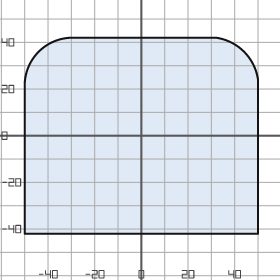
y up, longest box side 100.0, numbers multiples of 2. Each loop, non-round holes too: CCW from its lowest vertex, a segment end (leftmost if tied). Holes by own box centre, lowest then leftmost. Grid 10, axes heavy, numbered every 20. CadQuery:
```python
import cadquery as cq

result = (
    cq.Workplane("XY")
    .moveTo(-50.0, -42.0)
    .lineTo(50.0, -42.0)
    .lineTo(50.0, 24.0)
    .threePointArc((44.0, 36.0), (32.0, 42.0))
    .lineTo(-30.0, 42.0)
    .threePointArc((-44.0, 36.0), (-50.0, 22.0))
    .close()
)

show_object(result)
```